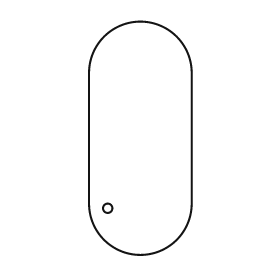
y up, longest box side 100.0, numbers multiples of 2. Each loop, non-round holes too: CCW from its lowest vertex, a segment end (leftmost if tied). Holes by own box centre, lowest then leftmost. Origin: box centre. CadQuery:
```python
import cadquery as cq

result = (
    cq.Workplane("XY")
    .moveTo(-22.0, -28.0)
    .threePointArc((0.0, -50.0), (22.0, -28.0))
    .lineTo(22.0, 28.0)
    .threePointArc((0.0, 50.0), (-22.0, 28.0))
    .close()
    .moveTo(-14.0, -30.0)
    .circle(2.0)
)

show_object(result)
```